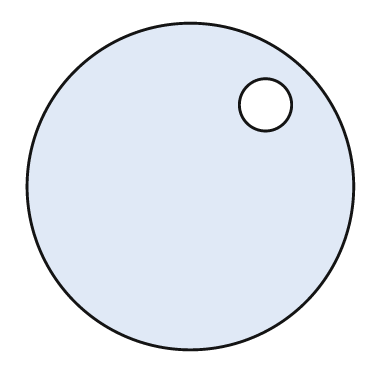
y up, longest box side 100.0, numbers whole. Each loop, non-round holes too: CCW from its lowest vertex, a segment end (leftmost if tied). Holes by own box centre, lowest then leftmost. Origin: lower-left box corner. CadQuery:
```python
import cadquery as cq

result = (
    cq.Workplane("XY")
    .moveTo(50.0, 50.0)
    .circle(50.0)
    .moveTo(73.0, 75.0)
    .circle(8.0)
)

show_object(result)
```